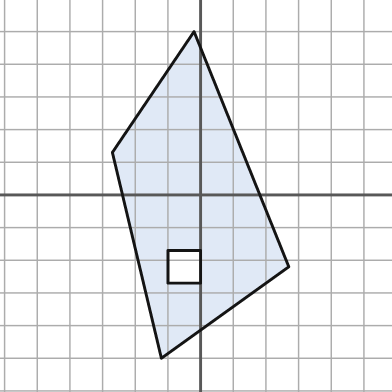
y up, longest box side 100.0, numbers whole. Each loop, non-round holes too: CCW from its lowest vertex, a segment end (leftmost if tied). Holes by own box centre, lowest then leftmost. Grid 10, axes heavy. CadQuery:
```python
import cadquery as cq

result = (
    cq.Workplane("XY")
    .moveTo(-12.0, -50.0)
    .lineTo(27.0, -22.0)
    .lineTo(-2.0, 50.0)
    .lineTo(-27.0, 13.0)
    .close()
    .moveTo(-10.0, -27.0)
    .lineTo(0.0, -27.0)
    .lineTo(0.0, -17.0)
    .lineTo(-10.0, -17.0)
    .close()
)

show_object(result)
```